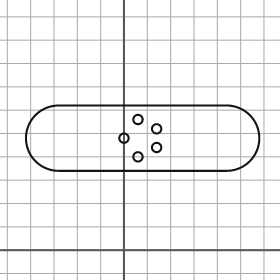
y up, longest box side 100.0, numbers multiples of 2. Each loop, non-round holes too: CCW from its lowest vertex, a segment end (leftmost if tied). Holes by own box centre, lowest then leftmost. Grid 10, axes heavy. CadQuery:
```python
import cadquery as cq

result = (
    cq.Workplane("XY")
    .moveTo(-28.0, 34.0)
    .lineTo(44.0, 34.0)
    .threePointArc((58.0, 48.0), (44.0, 62.0))
    .lineTo(-28.0, 62.0)
    .threePointArc((-42.0, 48.0), (-28.0, 34.0))
    .close()
    .moveTo(6.0, 40.0)
    .circle(2.0)
    .moveTo(14.0, 44.0)
    .circle(2.0)
    .moveTo(0.0, 48.0)
    .circle(2.0)
    .moveTo(14.0, 52.0)
    .circle(2.0)
    .moveTo(6.0, 56.0)
    .circle(2.0)
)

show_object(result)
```